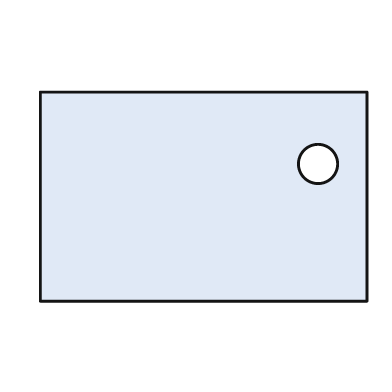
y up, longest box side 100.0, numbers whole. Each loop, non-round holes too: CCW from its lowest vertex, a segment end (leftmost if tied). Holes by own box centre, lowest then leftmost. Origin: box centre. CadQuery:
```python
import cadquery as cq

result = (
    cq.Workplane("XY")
    .moveTo(-50.0, -32.0)
    .lineTo(50.0, -32.0)
    .lineTo(50.0, 32.0)
    .lineTo(-50.0, 32.0)
    .close()
    .moveTo(35.0, 10.0)
    .circle(6.0)
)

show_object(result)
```